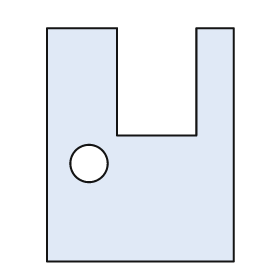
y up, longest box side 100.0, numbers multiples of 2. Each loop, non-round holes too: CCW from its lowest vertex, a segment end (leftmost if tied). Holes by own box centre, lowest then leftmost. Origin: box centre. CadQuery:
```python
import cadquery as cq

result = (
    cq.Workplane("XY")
    .moveTo(-40.0, -50.0)
    .lineTo(40.0, -50.0)
    .lineTo(40.0, 50.0)
    .lineTo(24.0, 50.0)
    .lineTo(24.0, 4.0)
    .lineTo(-10.0, 4.0)
    .lineTo(-10.0, 50.0)
    .lineTo(-40.0, 50.0)
    .close()
    .moveTo(-22.0, -8.0)
    .circle(8.0)
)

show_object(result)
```